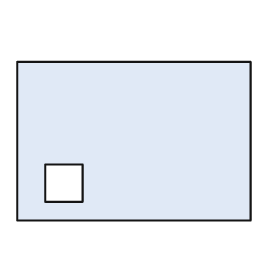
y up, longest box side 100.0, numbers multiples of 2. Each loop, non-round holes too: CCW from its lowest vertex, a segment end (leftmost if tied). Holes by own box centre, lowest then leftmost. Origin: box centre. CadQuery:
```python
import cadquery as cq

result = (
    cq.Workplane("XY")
    .moveTo(-50.0, -34.0)
    .lineTo(50.0, -34.0)
    .lineTo(50.0, 34.0)
    .lineTo(-50.0, 34.0)
    .close()
    .moveTo(-38.0, -26.0)
    .lineTo(-22.0, -26.0)
    .lineTo(-22.0, -10.0)
    .lineTo(-38.0, -10.0)
    .close()
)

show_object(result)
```